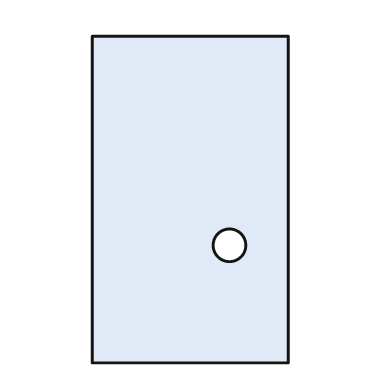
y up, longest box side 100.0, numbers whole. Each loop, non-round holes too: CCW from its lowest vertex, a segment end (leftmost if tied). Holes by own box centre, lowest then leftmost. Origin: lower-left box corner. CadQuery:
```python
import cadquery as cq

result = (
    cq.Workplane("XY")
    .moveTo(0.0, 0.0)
    .lineTo(60.0, 0.0)
    .lineTo(60.0, 100.0)
    .lineTo(0.0, 100.0)
    .close()
    .moveTo(42.0, 36.0)
    .circle(5.0)
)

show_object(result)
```